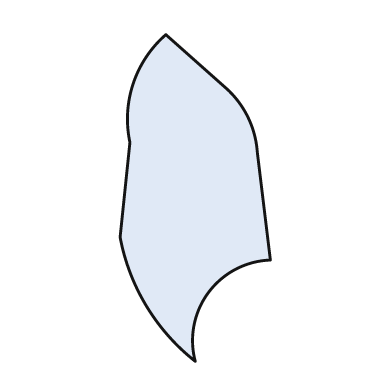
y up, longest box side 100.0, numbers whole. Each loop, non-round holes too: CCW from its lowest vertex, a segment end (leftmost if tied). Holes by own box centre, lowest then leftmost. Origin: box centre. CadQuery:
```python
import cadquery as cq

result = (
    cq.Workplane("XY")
    .moveTo(0.0, -50.0)
    .threePointArc((4.0, -29.0), (23.0, -19.0))
    .lineTo(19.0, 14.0)
    .threePointArc((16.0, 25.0), (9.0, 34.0))
    .lineTo(-9.0, 50.0)
    .threePointArc((-19.0, 35.0), (-20.0, 17.0))
    .lineTo(-23.0, -12.0)
    .threePointArc((-15.0, -33.0), (0.0, -50.0))
    .close()
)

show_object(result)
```